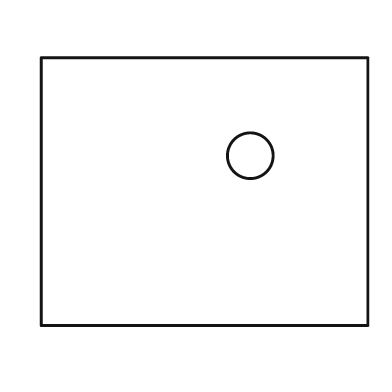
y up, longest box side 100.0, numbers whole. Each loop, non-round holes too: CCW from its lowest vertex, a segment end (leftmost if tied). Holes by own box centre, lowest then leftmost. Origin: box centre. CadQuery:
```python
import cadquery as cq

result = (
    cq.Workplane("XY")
    .moveTo(-50.0, -41.0)
    .lineTo(50.0, -41.0)
    .lineTo(50.0, 41.0)
    .lineTo(-50.0, 41.0)
    .close()
    .moveTo(14.0, 11.0)
    .circle(7.0)
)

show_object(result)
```